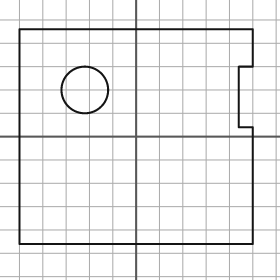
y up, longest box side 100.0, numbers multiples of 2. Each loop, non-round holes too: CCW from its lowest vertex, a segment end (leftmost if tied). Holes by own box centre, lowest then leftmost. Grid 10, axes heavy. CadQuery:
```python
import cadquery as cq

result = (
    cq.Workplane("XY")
    .moveTo(-50.0, -46.0)
    .lineTo(50.0, -46.0)
    .lineTo(50.0, 4.0)
    .lineTo(44.0, 4.0)
    .lineTo(44.0, 30.0)
    .lineTo(50.0, 30.0)
    .lineTo(50.0, 46.0)
    .lineTo(-50.0, 46.0)
    .close()
    .moveTo(-22.0, 20.0)
    .circle(10.0)
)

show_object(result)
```